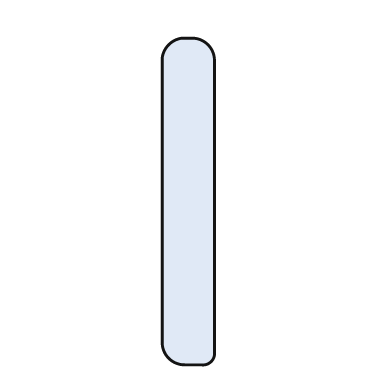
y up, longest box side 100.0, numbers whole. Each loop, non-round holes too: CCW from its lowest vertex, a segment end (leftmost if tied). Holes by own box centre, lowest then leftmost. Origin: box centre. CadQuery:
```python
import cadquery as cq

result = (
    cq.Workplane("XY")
    .moveTo(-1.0, -50.0)
    .lineTo(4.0, -50.0)
    .threePointArc((7.0, -49.0), (8.0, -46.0))
    .lineTo(8.0, 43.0)
    .threePointArc((6.0, 48.0), (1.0, 50.0))
    .lineTo(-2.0, 50.0)
    .threePointArc((-6.0, 48.0), (-8.0, 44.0))
    .lineTo(-8.0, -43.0)
    .threePointArc((-6.0, -48.0), (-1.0, -50.0))
    .close()
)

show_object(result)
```